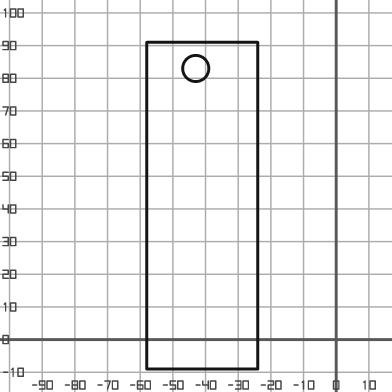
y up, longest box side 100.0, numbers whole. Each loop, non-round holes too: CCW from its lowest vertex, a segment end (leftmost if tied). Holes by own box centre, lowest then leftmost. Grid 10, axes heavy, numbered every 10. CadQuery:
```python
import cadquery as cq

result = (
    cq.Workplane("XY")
    .moveTo(-58.0, -9.0)
    .lineTo(-24.0, -9.0)
    .lineTo(-24.0, 91.0)
    .lineTo(-58.0, 91.0)
    .close()
    .moveTo(-43.0, 83.0)
    .circle(4.0)
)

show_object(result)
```